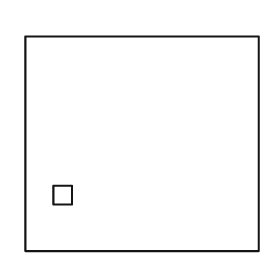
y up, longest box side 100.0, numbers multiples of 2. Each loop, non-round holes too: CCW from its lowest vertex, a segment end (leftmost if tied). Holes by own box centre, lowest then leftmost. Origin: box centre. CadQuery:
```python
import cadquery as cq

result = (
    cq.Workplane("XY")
    .moveTo(-50.0, -46.0)
    .lineTo(50.0, -46.0)
    .lineTo(50.0, 46.0)
    .lineTo(-50.0, 46.0)
    .close()
    .moveTo(-38.0, -26.0)
    .lineTo(-30.0, -26.0)
    .lineTo(-30.0, -18.0)
    .lineTo(-38.0, -18.0)
    .close()
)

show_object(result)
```